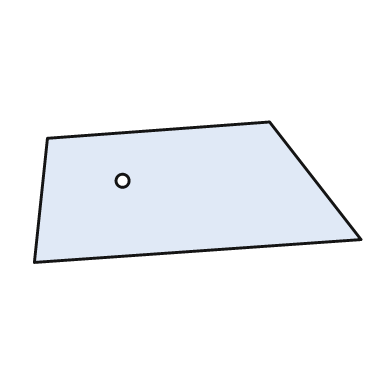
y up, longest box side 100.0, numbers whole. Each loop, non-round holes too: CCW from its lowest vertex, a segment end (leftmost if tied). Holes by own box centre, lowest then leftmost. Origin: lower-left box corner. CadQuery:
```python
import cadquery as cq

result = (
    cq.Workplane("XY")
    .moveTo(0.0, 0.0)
    .lineTo(100.0, 7.0)
    .lineTo(72.0, 43.0)
    .lineTo(4.0, 38.0)
    .close()
    .moveTo(27.0, 25.0)
    .circle(2.0)
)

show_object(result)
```